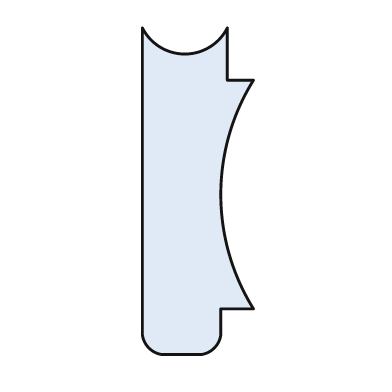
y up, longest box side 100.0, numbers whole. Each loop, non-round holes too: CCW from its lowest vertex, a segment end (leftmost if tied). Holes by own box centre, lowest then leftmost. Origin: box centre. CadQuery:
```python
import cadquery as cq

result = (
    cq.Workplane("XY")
    .moveTo(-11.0, -50.0)
    .lineTo(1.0, -50.0)
    .threePointArc((5.0, -48.0), (7.0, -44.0))
    .lineTo(7.0, -36.0)
    .lineTo(17.0, -36.0)
    .threePointArc((7.0, -1.0), (17.0, 34.0))
    .lineTo(9.0, 34.0)
    .lineTo(9.0, 50.0)
    .threePointArc((-4.0, 42.0), (-17.0, 50.0))
    .lineTo(-17.0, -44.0)
    .threePointArc((-15.0, -48.0), (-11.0, -50.0))
    .close()
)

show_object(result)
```